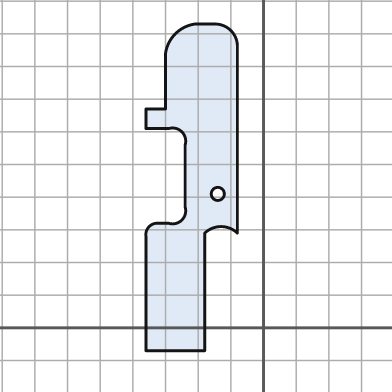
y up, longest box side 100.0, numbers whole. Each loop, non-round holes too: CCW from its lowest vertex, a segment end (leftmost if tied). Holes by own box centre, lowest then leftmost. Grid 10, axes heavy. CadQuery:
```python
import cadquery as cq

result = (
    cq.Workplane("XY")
    .moveTo(-36.0, -7.0)
    .lineTo(-18.0, -7.0)
    .lineTo(-18.0, 29.0)
    .threePointArc((-13.0, 31.0), (-8.0, 29.0))
    .lineTo(-8.0, 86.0)
    .threePointArc((-10.0, 91.0), (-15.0, 93.0))
    .lineTo(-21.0, 93.0)
    .threePointArc((-27.0, 90.0), (-30.0, 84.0))
    .lineTo(-30.0, 67.0)
    .lineTo(-36.0, 67.0)
    .lineTo(-36.0, 61.0)
    .lineTo(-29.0, 61.0)
    .threePointArc((-25.0, 60.0), (-24.0, 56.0))
    .lineTo(-24.0, 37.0)
    .threePointArc((-25.0, 33.0), (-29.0, 32.0))
    .lineTo(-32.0, 32.0)
    .threePointArc((-35.0, 31.0), (-36.0, 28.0))
    .close()
    .moveTo(-14.0, 41.0)
    .circle(2.0)
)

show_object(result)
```